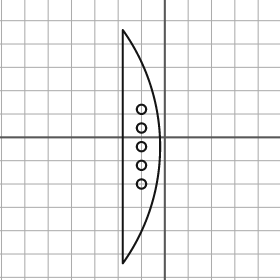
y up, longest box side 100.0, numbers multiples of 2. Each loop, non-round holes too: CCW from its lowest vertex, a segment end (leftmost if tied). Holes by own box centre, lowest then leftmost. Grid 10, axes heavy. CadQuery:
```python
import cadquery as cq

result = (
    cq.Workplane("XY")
    .moveTo(-18.0, -54.0)
    .threePointArc((-2.0, -4.0), (-18.0, 46.0))
    .close()
    .moveTo(-10.0, -20.0)
    .circle(2.0)
    .moveTo(-10.0, -12.0)
    .circle(2.0)
    .moveTo(-10.0, -4.0)
    .circle(2.0)
    .moveTo(-10.0, 4.0)
    .circle(2.0)
    .moveTo(-10.0, 12.0)
    .circle(2.0)
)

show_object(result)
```